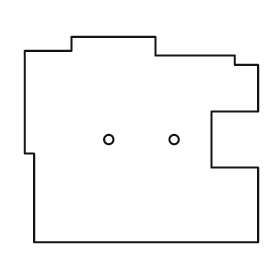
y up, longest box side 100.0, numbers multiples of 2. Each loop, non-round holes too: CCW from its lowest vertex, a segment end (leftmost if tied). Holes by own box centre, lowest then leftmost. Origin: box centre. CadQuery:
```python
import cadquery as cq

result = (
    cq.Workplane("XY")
    .moveTo(-46.0, -44.0)
    .lineTo(50.0, -44.0)
    .lineTo(50.0, -12.0)
    .lineTo(30.0, -12.0)
    .lineTo(30.0, 12.0)
    .lineTo(50.0, 12.0)
    .lineTo(50.0, 32.0)
    .lineTo(40.0, 32.0)
    .lineTo(40.0, 36.0)
    .lineTo(6.0, 36.0)
    .lineTo(6.0, 44.0)
    .lineTo(-30.0, 44.0)
    .lineTo(-30.0, 38.0)
    .lineTo(-50.0, 38.0)
    .lineTo(-50.0, -6.0)
    .lineTo(-46.0, -6.0)
    .close()
    .moveTo(-14.0, 0.0)
    .circle(2.0)
    .moveTo(14.0, 0.0)
    .circle(2.0)
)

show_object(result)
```